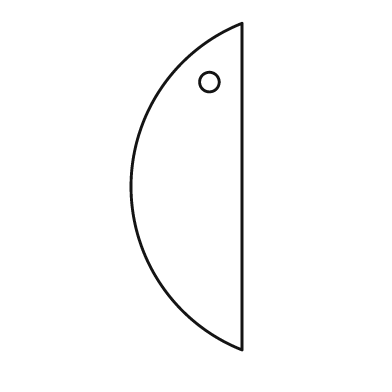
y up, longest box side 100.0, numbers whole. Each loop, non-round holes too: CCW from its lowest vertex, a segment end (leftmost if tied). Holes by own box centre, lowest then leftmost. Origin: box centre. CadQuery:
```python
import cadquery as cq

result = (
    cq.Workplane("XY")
    .moveTo(17.0, -50.0)
    .lineTo(17.0, 50.0)
    .threePointArc((-17.0, 0.0), (17.0, -50.0))
    .close()
    .moveTo(7.0, 32.0)
    .circle(3.0)
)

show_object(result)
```